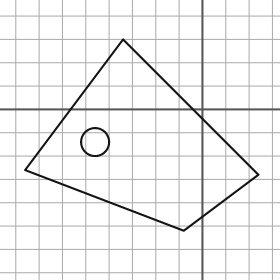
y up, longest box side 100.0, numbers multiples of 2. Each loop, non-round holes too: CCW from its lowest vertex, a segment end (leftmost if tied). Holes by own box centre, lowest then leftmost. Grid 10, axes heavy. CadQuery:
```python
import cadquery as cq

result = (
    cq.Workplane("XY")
    .moveTo(-8.0, -52.0)
    .lineTo(24.0, -28.0)
    .lineTo(-34.0, 30.0)
    .lineTo(-76.0, -26.0)
    .close()
    .moveTo(-46.0, -14.0)
    .circle(6.0)
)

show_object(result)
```